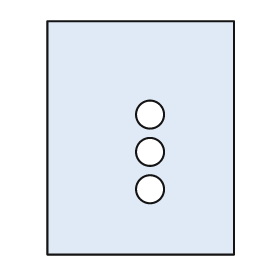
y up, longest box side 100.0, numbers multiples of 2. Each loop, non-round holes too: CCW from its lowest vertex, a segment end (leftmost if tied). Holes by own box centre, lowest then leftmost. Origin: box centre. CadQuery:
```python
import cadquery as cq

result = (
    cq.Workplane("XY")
    .moveTo(-40.0, -50.0)
    .lineTo(40.0, -50.0)
    .lineTo(40.0, 50.0)
    .lineTo(-40.0, 50.0)
    .close()
    .moveTo(4.0, -22.0)
    .circle(6.0)
    .moveTo(4.0, -6.0)
    .circle(6.0)
    .moveTo(4.0, 10.0)
    .circle(6.0)
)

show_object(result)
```